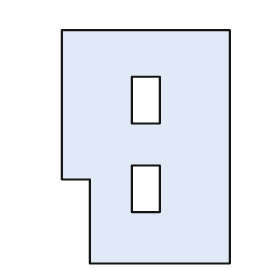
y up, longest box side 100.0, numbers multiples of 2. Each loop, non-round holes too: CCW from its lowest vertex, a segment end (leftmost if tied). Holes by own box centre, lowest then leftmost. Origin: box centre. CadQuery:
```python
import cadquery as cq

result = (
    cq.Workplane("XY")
    .moveTo(-24.0, -50.0)
    .lineTo(36.0, -50.0)
    .lineTo(36.0, 50.0)
    .lineTo(-36.0, 50.0)
    .lineTo(-36.0, -14.0)
    .lineTo(-24.0, -14.0)
    .close()
    .moveTo(-6.0, -28.0)
    .lineTo(6.0, -28.0)
    .lineTo(6.0, -8.0)
    .lineTo(-6.0, -8.0)
    .close()
    .moveTo(-6.0, 10.0)
    .lineTo(6.0, 10.0)
    .lineTo(6.0, 30.0)
    .lineTo(-6.0, 30.0)
    .close()
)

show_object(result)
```